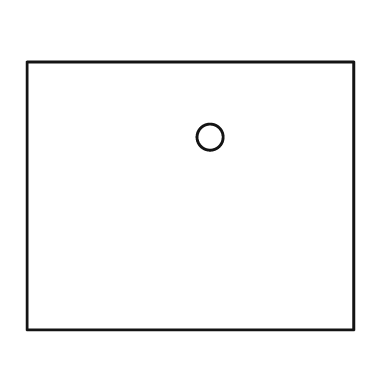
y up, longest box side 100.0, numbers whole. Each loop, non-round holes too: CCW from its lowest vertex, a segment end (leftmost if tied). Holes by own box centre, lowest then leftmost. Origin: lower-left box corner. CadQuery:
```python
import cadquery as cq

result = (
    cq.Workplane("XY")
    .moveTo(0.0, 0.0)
    .lineTo(100.0, 0.0)
    .lineTo(100.0, 82.0)
    .lineTo(0.0, 82.0)
    .close()
    .moveTo(56.0, 59.0)
    .circle(4.0)
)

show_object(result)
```